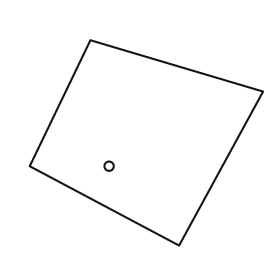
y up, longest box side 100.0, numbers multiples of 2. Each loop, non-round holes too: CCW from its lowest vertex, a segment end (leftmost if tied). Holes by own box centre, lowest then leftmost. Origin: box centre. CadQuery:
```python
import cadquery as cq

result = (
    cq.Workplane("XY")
    .moveTo(14.0, -44.0)
    .lineTo(50.0, 22.0)
    .lineTo(-24.0, 44.0)
    .lineTo(-50.0, -10.0)
    .close()
    .moveTo(-16.0, -10.0)
    .circle(2.0)
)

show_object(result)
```